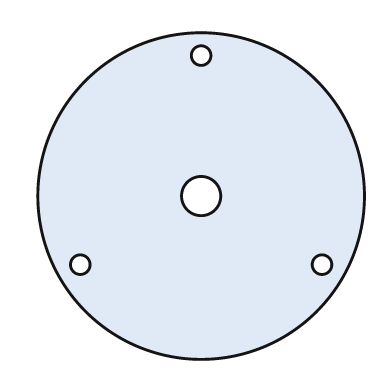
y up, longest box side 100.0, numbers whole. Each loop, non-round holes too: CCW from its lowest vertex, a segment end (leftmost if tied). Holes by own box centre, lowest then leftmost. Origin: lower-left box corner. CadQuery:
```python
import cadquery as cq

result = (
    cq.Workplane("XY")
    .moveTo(50.0, 50.0)
    .circle(50.0)
    .moveTo(13.0, 29.0)
    .circle(3.0)
    .moveTo(87.0, 29.0)
    .circle(3.0)
    .moveTo(50.0, 50.0)
    .circle(6.0)
    .moveTo(50.0, 93.0)
    .circle(3.0)
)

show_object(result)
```